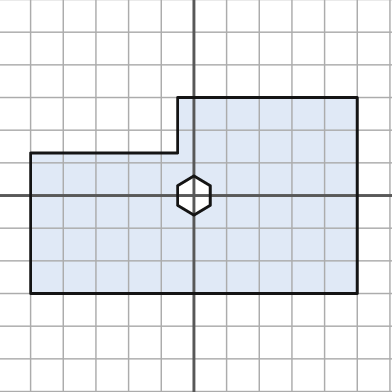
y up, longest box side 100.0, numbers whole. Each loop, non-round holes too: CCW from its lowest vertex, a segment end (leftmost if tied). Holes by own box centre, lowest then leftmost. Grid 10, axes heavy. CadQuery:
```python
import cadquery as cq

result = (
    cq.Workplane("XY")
    .moveTo(-50.0, -30.0)
    .lineTo(50.0, -30.0)
    .lineTo(50.0, 30.0)
    .lineTo(-5.0, 30.0)
    .lineTo(-5.0, 13.0)
    .lineTo(-50.0, 13.0)
    .close()
    .moveTo(0.0, -6.0)
    .lineTo(5.0, -3.0)
    .lineTo(5.0, 3.0)
    .lineTo(0.0, 6.0)
    .lineTo(-5.0, 3.0)
    .lineTo(-5.0, -3.0)
    .close()
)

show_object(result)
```